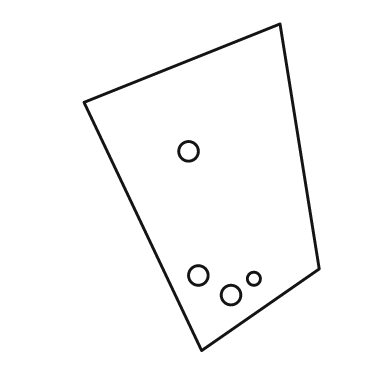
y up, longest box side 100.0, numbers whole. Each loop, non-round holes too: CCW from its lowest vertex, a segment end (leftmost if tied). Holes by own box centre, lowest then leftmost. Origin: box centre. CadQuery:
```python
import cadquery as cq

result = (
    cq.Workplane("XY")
    .moveTo(0.0, -50.0)
    .lineTo(36.0, -25.0)
    .lineTo(24.0, 50.0)
    .lineTo(-36.0, 26.0)
    .close()
    .moveTo(9.0, -33.0)
    .circle(3.0)
    .moveTo(16.0, -28.0)
    .circle(2.0)
    .moveTo(-1.0, -27.0)
    .circle(3.0)
    .moveTo(-4.0, 11.0)
    .circle(3.0)
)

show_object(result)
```